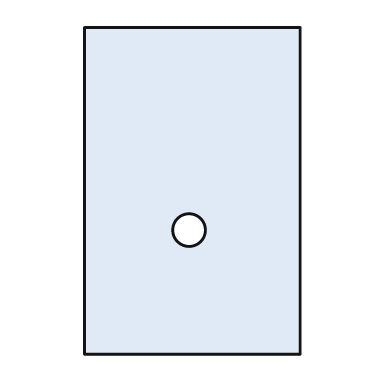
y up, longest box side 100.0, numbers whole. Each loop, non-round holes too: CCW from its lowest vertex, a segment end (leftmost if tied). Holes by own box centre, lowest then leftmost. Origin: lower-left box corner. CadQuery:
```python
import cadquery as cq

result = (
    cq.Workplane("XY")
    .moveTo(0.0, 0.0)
    .lineTo(66.0, 0.0)
    .lineTo(66.0, 100.0)
    .lineTo(0.0, 100.0)
    .close()
    .moveTo(32.0, 38.0)
    .circle(5.0)
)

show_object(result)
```